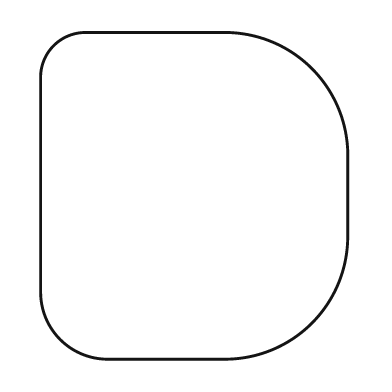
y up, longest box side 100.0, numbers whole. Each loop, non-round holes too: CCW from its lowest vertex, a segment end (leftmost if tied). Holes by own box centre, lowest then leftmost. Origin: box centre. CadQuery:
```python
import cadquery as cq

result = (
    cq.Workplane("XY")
    .moveTo(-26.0, -50.0)
    .lineTo(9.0, -50.0)
    .threePointArc((36.0, -39.0), (47.0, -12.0))
    .lineTo(47.0, 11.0)
    .threePointArc((36.0, 39.0), (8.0, 50.0))
    .lineTo(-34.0, 50.0)
    .threePointArc((-43.0, 46.0), (-47.0, 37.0))
    .lineTo(-47.0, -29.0)
    .threePointArc((-41.0, -44.0), (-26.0, -50.0))
    .close()
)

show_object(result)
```